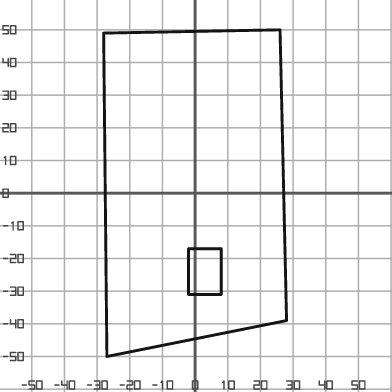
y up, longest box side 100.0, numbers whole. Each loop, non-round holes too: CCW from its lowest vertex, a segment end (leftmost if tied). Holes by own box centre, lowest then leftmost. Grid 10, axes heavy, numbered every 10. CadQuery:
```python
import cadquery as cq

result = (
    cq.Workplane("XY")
    .moveTo(-27.0, -50.0)
    .lineTo(28.0, -39.0)
    .lineTo(26.0, 50.0)
    .lineTo(-28.0, 49.0)
    .close()
    .moveTo(-2.0, -31.0)
    .lineTo(8.0, -31.0)
    .lineTo(8.0, -17.0)
    .lineTo(-2.0, -17.0)
    .close()
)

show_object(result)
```